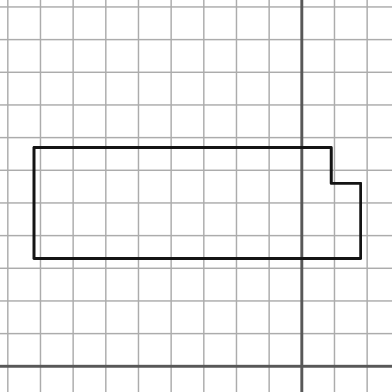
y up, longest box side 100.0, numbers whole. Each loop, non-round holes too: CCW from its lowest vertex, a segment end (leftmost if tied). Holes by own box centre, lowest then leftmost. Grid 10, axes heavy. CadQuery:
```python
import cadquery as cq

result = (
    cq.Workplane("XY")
    .moveTo(-82.0, 33.0)
    .lineTo(18.0, 33.0)
    .lineTo(18.0, 56.0)
    .lineTo(9.0, 56.0)
    .lineTo(9.0, 67.0)
    .lineTo(-82.0, 67.0)
    .close()
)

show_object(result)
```